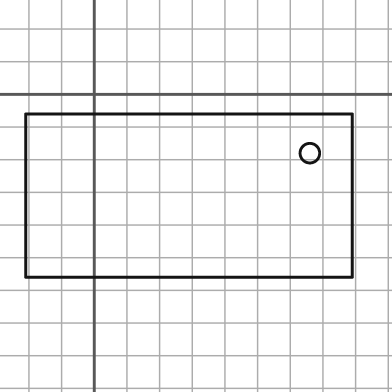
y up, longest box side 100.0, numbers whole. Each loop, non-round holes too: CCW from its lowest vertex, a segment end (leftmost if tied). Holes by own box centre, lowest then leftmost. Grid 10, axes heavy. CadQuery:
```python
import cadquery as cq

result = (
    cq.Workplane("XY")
    .moveTo(-21.0, -56.0)
    .lineTo(79.0, -56.0)
    .lineTo(79.0, -6.0)
    .lineTo(-21.0, -6.0)
    .close()
    .moveTo(66.0, -18.0)
    .circle(3.0)
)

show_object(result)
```